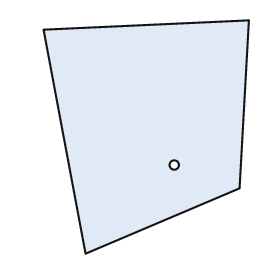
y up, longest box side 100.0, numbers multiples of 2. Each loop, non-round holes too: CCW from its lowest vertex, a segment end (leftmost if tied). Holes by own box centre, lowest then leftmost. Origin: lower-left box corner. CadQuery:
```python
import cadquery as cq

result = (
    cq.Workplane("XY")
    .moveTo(18.0, 0.0)
    .lineTo(84.0, 28.0)
    .lineTo(88.0, 100.0)
    .lineTo(0.0, 96.0)
    .close()
    .moveTo(56.0, 38.0)
    .circle(2.0)
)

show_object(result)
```